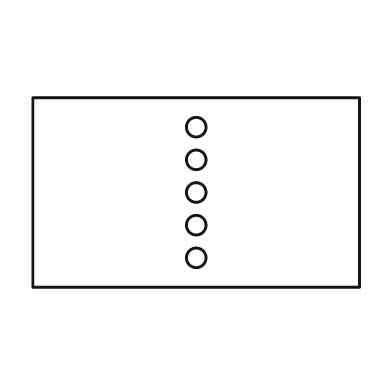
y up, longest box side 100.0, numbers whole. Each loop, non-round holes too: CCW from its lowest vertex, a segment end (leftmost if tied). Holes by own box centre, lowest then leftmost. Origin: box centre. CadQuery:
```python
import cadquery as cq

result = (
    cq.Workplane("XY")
    .moveTo(-50.0, -29.0)
    .lineTo(50.0, -29.0)
    .lineTo(50.0, 29.0)
    .lineTo(-50.0, 29.0)
    .close()
    .moveTo(0.0, -20.0)
    .circle(3.0)
    .moveTo(0.0, -10.0)
    .circle(3.0)
    .moveTo(0.0, 0.0)
    .circle(3.0)
    .moveTo(0.0, 10.0)
    .circle(3.0)
    .moveTo(0.0, 20.0)
    .circle(3.0)
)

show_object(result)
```